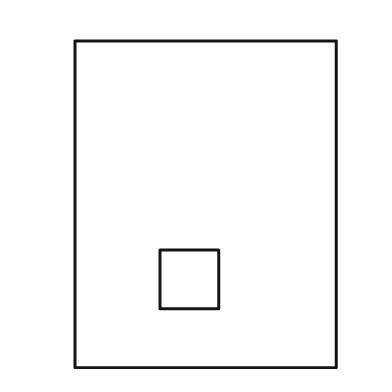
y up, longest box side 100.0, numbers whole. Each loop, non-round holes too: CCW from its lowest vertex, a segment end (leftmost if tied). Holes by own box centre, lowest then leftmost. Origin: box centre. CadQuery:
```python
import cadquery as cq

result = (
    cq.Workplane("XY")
    .moveTo(-40.0, -50.0)
    .lineTo(40.0, -50.0)
    .lineTo(40.0, 50.0)
    .lineTo(-40.0, 50.0)
    .close()
    .moveTo(-14.0, -32.0)
    .lineTo(4.0, -32.0)
    .lineTo(4.0, -14.0)
    .lineTo(-14.0, -14.0)
    .close()
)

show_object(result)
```